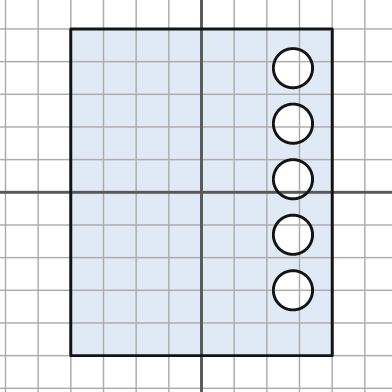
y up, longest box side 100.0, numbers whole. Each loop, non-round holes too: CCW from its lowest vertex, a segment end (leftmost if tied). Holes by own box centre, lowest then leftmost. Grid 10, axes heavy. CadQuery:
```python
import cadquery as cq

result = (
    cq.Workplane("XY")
    .moveTo(-40.0, -50.0)
    .lineTo(40.0, -50.0)
    .lineTo(40.0, 50.0)
    .lineTo(-40.0, 50.0)
    .close()
    .moveTo(28.0, -30.0)
    .circle(6.0)
    .moveTo(28.0, -13.0)
    .circle(6.0)
    .moveTo(28.0, 4.0)
    .circle(6.0)
    .moveTo(28.0, 21.0)
    .circle(6.0)
    .moveTo(28.0, 38.0)
    .circle(6.0)
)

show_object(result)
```